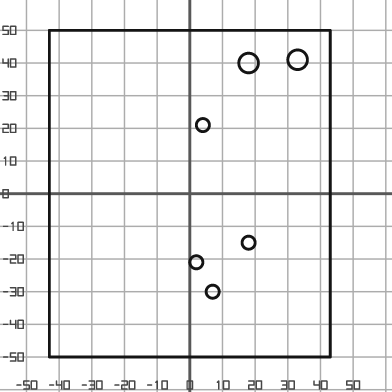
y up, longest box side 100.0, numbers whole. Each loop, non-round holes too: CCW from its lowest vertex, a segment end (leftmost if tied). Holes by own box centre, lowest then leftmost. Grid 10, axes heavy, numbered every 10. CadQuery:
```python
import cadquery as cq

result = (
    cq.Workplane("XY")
    .moveTo(-43.0, -50.0)
    .lineTo(43.0, -50.0)
    .lineTo(43.0, 50.0)
    .lineTo(-43.0, 50.0)
    .close()
    .moveTo(7.0, -30.0)
    .circle(2.0)
    .moveTo(2.0, -21.0)
    .circle(2.0)
    .moveTo(18.0, -15.0)
    .circle(2.0)
    .moveTo(4.0, 21.0)
    .circle(2.0)
    .moveTo(18.0, 40.0)
    .circle(3.0)
    .moveTo(33.0, 41.0)
    .circle(3.0)
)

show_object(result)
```